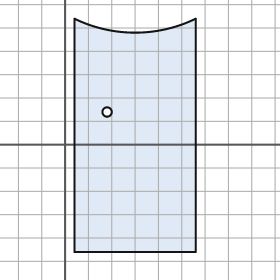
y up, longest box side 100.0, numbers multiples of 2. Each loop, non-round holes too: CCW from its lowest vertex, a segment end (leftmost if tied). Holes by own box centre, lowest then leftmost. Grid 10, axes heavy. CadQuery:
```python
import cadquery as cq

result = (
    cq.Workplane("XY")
    .moveTo(4.0, -46.0)
    .lineTo(56.0, -46.0)
    .lineTo(56.0, 54.0)
    .threePointArc((30.0, 48.0), (4.0, 54.0))
    .close()
    .moveTo(18.0, 14.0)
    .circle(2.0)
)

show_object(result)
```